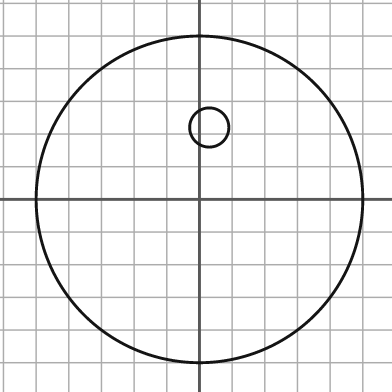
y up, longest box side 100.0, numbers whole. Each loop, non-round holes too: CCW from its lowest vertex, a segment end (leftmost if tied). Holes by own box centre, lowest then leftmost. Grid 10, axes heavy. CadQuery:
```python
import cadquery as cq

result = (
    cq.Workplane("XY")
    .moveTo(0.0, 0.0)
    .circle(50.0)
    .moveTo(3.0, 22.0)
    .circle(6.0)
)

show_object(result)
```